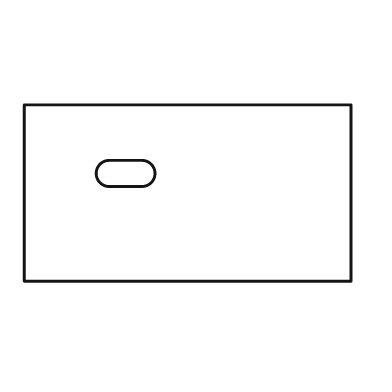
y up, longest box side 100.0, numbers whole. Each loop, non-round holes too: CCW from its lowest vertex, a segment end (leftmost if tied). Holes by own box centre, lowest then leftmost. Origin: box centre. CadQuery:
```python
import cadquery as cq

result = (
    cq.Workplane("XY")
    .moveTo(-50.0, -27.0)
    .lineTo(50.0, -27.0)
    .lineTo(50.0, 27.0)
    .lineTo(-50.0, 27.0)
    .close()
    .moveTo(-24.0, 2.0)
    .lineTo(-14.0, 2.0)
    .threePointArc((-10.0, 6.0), (-14.0, 10.0))
    .lineTo(-24.0, 10.0)
    .threePointArc((-28.0, 6.0), (-24.0, 2.0))
    .close()
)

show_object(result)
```